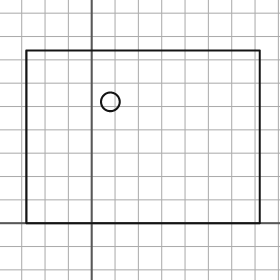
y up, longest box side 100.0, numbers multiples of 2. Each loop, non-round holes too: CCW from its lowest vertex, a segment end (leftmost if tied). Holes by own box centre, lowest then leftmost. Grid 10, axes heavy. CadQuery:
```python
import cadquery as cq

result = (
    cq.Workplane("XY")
    .moveTo(-28.0, 0.0)
    .lineTo(72.0, 0.0)
    .lineTo(72.0, 74.0)
    .lineTo(-28.0, 74.0)
    .close()
    .moveTo(8.0, 52.0)
    .circle(4.0)
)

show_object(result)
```